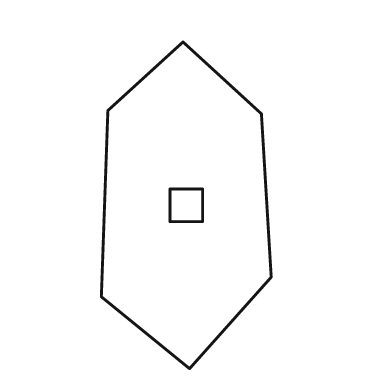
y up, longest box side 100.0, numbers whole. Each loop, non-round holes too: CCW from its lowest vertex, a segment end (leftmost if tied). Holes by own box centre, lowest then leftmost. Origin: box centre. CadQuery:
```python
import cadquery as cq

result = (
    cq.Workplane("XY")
    .moveTo(1.0, -50.0)
    .lineTo(26.0, -22.0)
    .lineTo(23.0, 28.0)
    .lineTo(-1.0, 50.0)
    .lineTo(-24.0, 29.0)
    .lineTo(-26.0, -28.0)
    .close()
    .moveTo(-5.0, -5.0)
    .lineTo(5.0, -5.0)
    .lineTo(5.0, 5.0)
    .lineTo(-5.0, 5.0)
    .close()
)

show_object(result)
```